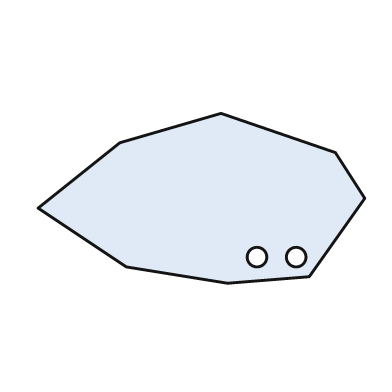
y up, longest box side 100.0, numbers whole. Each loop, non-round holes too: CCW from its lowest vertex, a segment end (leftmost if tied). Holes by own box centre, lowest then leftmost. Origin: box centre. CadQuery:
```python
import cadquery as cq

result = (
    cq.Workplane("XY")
    .moveTo(8.0, -26.0)
    .lineTo(33.0, -24.0)
    .lineTo(50.0, 0.0)
    .lineTo(41.0, 14.0)
    .lineTo(6.0, 26.0)
    .lineTo(-25.0, 17.0)
    .lineTo(-50.0, -3.0)
    .lineTo(-23.0, -21.0)
    .close()
    .moveTo(17.0, -18.0)
    .circle(3.0)
    .moveTo(29.0, -18.0)
    .circle(3.0)
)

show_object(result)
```